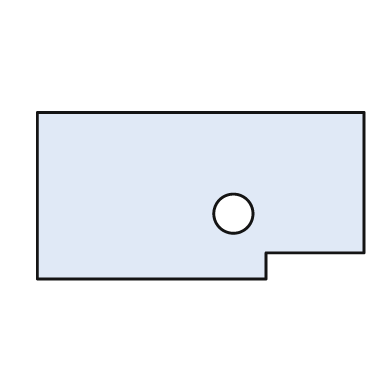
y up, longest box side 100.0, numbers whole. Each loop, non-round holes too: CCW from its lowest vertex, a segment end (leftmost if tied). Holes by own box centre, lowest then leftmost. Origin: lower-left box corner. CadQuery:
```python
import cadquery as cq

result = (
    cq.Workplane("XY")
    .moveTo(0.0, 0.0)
    .lineTo(70.0, 0.0)
    .lineTo(70.0, 8.0)
    .lineTo(100.0, 8.0)
    .lineTo(100.0, 51.0)
    .lineTo(0.0, 51.0)
    .close()
    .moveTo(60.0, 20.0)
    .circle(6.0)
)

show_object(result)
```